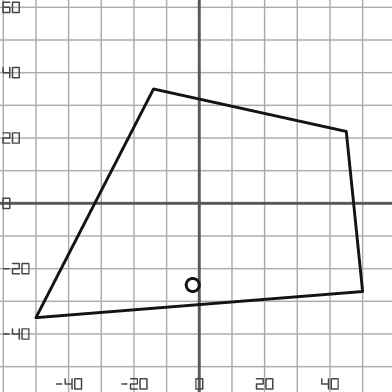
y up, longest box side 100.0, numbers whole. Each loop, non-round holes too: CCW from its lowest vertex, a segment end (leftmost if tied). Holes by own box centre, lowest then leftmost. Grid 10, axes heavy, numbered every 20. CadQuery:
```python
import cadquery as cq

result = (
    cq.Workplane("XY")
    .moveTo(-50.0, -35.0)
    .lineTo(50.0, -27.0)
    .lineTo(45.0, 22.0)
    .lineTo(-14.0, 35.0)
    .close()
    .moveTo(-2.0, -25.0)
    .circle(2.0)
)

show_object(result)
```